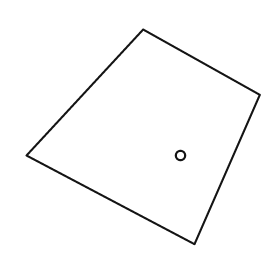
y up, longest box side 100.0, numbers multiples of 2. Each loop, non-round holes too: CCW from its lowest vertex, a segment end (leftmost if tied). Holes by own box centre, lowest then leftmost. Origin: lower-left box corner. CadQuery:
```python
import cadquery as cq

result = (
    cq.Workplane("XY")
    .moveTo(72.0, 0.0)
    .lineTo(100.0, 64.0)
    .lineTo(50.0, 92.0)
    .lineTo(0.0, 38.0)
    .close()
    .moveTo(66.0, 38.0)
    .circle(2.0)
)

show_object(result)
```